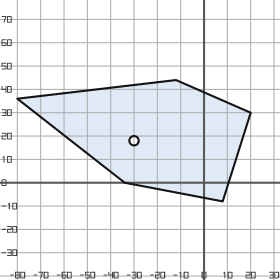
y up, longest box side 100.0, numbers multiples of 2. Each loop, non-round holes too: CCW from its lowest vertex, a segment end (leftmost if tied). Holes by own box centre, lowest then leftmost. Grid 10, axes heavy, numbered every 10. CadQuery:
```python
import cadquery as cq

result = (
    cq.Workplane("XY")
    .moveTo(8.0, -8.0)
    .lineTo(20.0, 30.0)
    .lineTo(-12.0, 44.0)
    .lineTo(-80.0, 36.0)
    .lineTo(-34.0, 0.0)
    .close()
    .moveTo(-30.0, 18.0)
    .circle(2.0)
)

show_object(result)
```